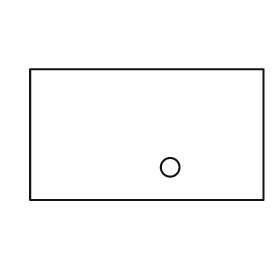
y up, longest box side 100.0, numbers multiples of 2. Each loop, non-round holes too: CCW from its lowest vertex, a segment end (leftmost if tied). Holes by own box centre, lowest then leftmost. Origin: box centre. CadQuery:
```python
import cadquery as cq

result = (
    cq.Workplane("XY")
    .moveTo(-50.0, -28.0)
    .lineTo(50.0, -28.0)
    .lineTo(50.0, 28.0)
    .lineTo(-50.0, 28.0)
    .close()
    .moveTo(10.0, -14.0)
    .circle(4.0)
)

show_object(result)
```